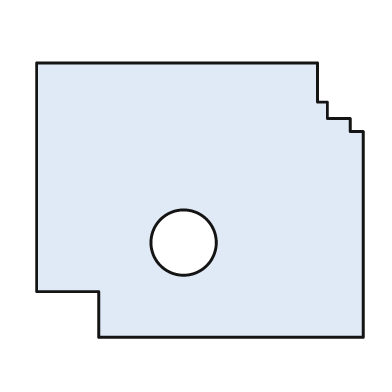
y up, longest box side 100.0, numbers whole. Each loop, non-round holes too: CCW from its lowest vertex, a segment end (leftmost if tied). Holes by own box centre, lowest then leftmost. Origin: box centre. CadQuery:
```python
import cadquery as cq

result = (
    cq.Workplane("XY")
    .moveTo(-31.0, -42.0)
    .lineTo(50.0, -42.0)
    .lineTo(50.0, 21.0)
    .lineTo(46.0, 21.0)
    .lineTo(46.0, 25.0)
    .lineTo(39.0, 25.0)
    .lineTo(39.0, 30.0)
    .lineTo(36.0, 30.0)
    .lineTo(36.0, 42.0)
    .lineTo(-50.0, 42.0)
    .lineTo(-50.0, -28.0)
    .lineTo(-31.0, -28.0)
    .close()
    .moveTo(-5.0, -13.0)
    .circle(10.0)
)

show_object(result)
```